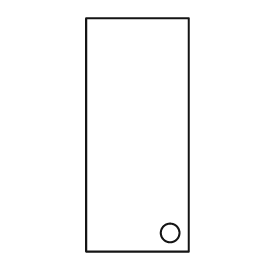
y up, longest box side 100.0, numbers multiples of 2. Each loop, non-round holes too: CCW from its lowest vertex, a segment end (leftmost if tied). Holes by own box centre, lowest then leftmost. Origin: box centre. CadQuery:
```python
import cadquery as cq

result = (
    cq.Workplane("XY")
    .moveTo(-22.0, -50.0)
    .lineTo(22.0, -50.0)
    .lineTo(22.0, 50.0)
    .lineTo(-22.0, 50.0)
    .close()
    .moveTo(14.0, -42.0)
    .circle(4.0)
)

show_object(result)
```